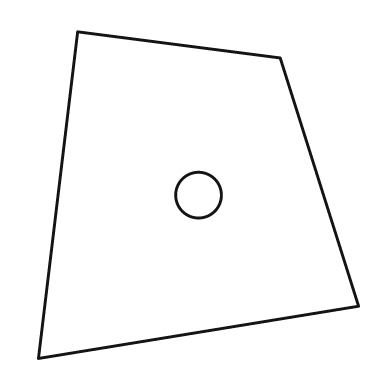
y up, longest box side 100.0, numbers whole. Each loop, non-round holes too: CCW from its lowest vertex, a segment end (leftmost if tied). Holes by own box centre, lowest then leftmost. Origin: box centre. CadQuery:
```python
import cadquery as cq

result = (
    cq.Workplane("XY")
    .moveTo(-49.0, -50.0)
    .lineTo(49.0, -34.0)
    .lineTo(25.0, 42.0)
    .lineTo(-37.0, 50.0)
    .close()
    .moveTo(0.0, 0.0)
    .circle(7.0)
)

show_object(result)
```